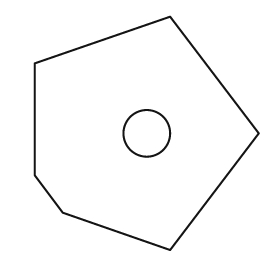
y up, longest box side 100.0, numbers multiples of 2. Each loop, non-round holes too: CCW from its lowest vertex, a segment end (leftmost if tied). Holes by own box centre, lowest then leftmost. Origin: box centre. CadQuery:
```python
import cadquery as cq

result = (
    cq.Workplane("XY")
    .moveTo(10.0, -50.0)
    .lineTo(48.0, 0.0)
    .lineTo(10.0, 50.0)
    .lineTo(-48.0, 30.0)
    .lineTo(-48.0, -18.0)
    .lineTo(-36.0, -34.0)
    .close()
    .moveTo(0.0, 0.0)
    .circle(10.0)
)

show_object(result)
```